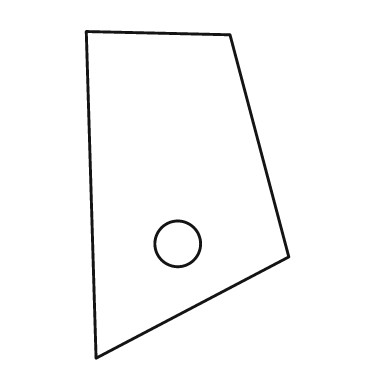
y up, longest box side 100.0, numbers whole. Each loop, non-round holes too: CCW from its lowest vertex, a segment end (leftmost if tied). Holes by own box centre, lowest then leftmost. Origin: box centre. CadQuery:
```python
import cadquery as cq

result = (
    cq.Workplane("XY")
    .moveTo(-28.0, -50.0)
    .lineTo(31.0, -19.0)
    .lineTo(13.0, 49.0)
    .lineTo(-31.0, 50.0)
    .close()
    .moveTo(-3.0, -15.0)
    .circle(7.0)
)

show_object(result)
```